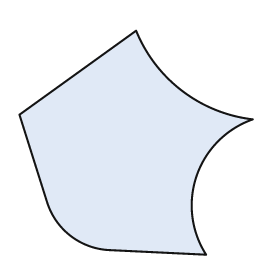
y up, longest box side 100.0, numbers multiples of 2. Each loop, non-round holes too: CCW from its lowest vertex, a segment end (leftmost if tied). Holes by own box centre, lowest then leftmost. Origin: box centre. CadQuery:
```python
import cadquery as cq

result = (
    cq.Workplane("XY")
    .moveTo(30.0, -48.0)
    .threePointArc((26.0, -14.0), (50.0, 10.0))
    .threePointArc((20.0, 22.0), (0.0, 48.0))
    .lineTo(-50.0, 12.0)
    .lineTo(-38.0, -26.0)
    .threePointArc((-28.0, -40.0), (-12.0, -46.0))
    .close()
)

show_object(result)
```